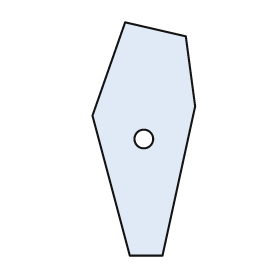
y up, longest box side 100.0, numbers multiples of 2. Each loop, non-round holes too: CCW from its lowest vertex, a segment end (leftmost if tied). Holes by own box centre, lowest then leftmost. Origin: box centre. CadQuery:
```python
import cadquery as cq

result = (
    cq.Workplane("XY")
    .moveTo(-6.0, -50.0)
    .lineTo(8.0, -50.0)
    .lineTo(22.0, 14.0)
    .lineTo(18.0, 44.0)
    .lineTo(-8.0, 50.0)
    .lineTo(-22.0, 10.0)
    .close()
    .moveTo(0.0, 0.0)
    .circle(4.0)
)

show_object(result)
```